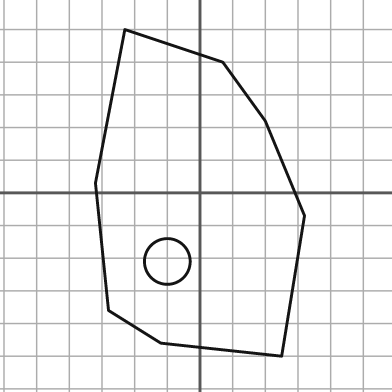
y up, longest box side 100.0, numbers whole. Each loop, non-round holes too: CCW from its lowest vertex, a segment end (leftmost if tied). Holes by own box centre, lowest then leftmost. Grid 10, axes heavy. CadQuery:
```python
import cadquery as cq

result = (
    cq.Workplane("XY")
    .moveTo(25.0, -50.0)
    .lineTo(32.0, -7.0)
    .lineTo(20.0, 22.0)
    .lineTo(7.0, 40.0)
    .lineTo(-23.0, 50.0)
    .lineTo(-32.0, 3.0)
    .lineTo(-28.0, -36.0)
    .lineTo(-12.0, -46.0)
    .close()
    .moveTo(-10.0, -21.0)
    .circle(7.0)
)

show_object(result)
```